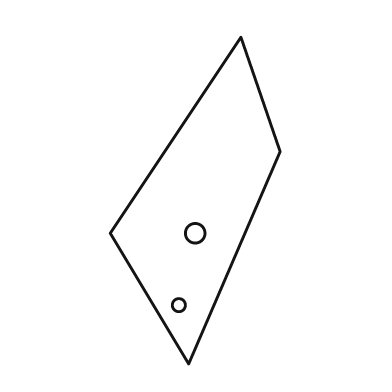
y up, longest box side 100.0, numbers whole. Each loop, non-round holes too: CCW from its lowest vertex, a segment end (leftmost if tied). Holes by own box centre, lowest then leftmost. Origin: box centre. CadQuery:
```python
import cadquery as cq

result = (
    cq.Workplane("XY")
    .moveTo(-2.0, -50.0)
    .lineTo(26.0, 15.0)
    .lineTo(14.0, 50.0)
    .lineTo(-26.0, -10.0)
    .close()
    .moveTo(-5.0, -32.0)
    .circle(2.0)
    .moveTo(0.0, -10.0)
    .circle(3.0)
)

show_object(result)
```